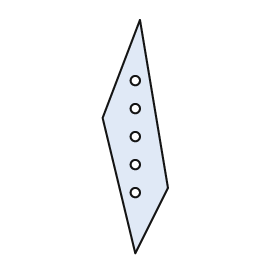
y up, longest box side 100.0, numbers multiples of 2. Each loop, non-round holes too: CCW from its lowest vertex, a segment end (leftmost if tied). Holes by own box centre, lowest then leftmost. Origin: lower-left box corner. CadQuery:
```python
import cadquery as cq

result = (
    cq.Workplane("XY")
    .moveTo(14.0, 0.0)
    .lineTo(28.0, 28.0)
    .lineTo(16.0, 100.0)
    .lineTo(0.0, 58.0)
    .close()
    .moveTo(14.0, 26.0)
    .circle(2.0)
    .moveTo(14.0, 38.0)
    .circle(2.0)
    .moveTo(14.0, 50.0)
    .circle(2.0)
    .moveTo(14.0, 62.0)
    .circle(2.0)
    .moveTo(14.0, 74.0)
    .circle(2.0)
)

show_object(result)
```